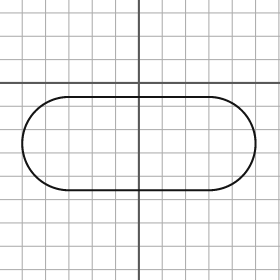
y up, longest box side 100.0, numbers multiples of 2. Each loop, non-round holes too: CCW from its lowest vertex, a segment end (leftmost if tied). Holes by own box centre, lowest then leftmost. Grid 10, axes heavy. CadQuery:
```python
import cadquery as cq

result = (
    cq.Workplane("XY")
    .moveTo(-30.0, -46.0)
    .lineTo(30.0, -46.0)
    .threePointArc((50.0, -26.0), (30.0, -6.0))
    .lineTo(-30.0, -6.0)
    .threePointArc((-50.0, -26.0), (-30.0, -46.0))
    .close()
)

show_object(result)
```